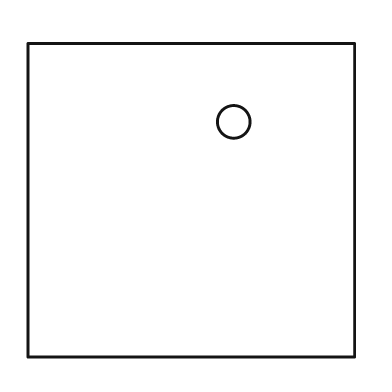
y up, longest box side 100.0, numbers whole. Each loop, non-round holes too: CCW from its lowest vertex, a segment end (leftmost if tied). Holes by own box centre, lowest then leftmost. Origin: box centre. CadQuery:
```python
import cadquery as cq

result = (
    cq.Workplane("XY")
    .moveTo(-50.0, -48.0)
    .lineTo(50.0, -48.0)
    .lineTo(50.0, 48.0)
    .lineTo(-50.0, 48.0)
    .close()
    .moveTo(13.0, 24.0)
    .circle(5.0)
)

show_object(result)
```